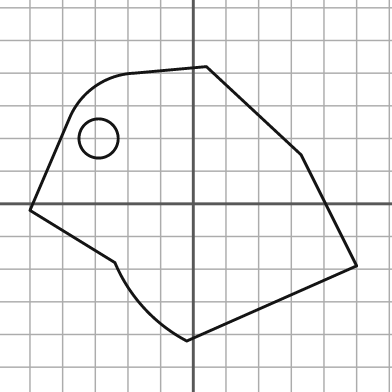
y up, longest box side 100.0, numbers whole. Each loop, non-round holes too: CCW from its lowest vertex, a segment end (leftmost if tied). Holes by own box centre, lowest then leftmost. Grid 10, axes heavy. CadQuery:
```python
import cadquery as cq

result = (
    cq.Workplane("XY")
    .moveTo(-2.0, -42.0)
    .lineTo(50.0, -19.0)
    .lineTo(33.0, 15.0)
    .lineTo(4.0, 42.0)
    .lineTo(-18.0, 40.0)
    .threePointArc((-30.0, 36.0), (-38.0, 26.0))
    .lineTo(-50.0, -2.0)
    .lineTo(-24.0, -18.0)
    .threePointArc((-15.0, -32.0), (-2.0, -42.0))
    .close()
    .moveTo(-29.0, 20.0)
    .circle(6.0)
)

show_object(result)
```